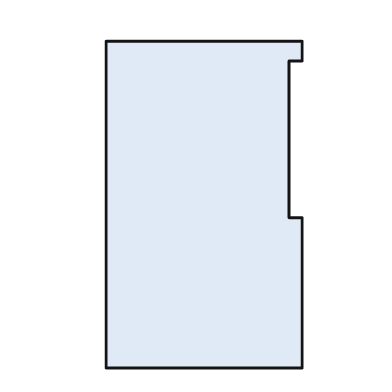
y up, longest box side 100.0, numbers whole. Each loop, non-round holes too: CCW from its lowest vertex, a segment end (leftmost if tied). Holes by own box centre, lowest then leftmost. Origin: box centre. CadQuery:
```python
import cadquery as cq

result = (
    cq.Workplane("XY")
    .moveTo(-30.0, -50.0)
    .lineTo(30.0, -50.0)
    .lineTo(30.0, -4.0)
    .lineTo(26.0, -4.0)
    .lineTo(26.0, 44.0)
    .lineTo(30.0, 44.0)
    .lineTo(30.0, 50.0)
    .lineTo(-30.0, 50.0)
    .close()
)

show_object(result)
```